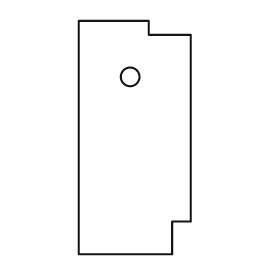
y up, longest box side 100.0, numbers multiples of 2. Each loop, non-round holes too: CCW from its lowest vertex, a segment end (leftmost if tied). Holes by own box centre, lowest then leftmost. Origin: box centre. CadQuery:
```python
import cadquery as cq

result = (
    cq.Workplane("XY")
    .moveTo(-24.0, -50.0)
    .lineTo(16.0, -50.0)
    .lineTo(16.0, -36.0)
    .lineTo(24.0, -36.0)
    .lineTo(24.0, 44.0)
    .lineTo(6.0, 44.0)
    .lineTo(6.0, 50.0)
    .lineTo(-24.0, 50.0)
    .close()
    .moveTo(-2.0, 26.0)
    .circle(4.0)
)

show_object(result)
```